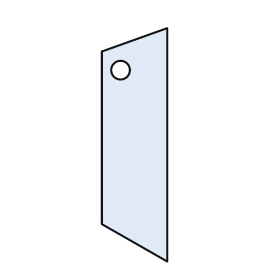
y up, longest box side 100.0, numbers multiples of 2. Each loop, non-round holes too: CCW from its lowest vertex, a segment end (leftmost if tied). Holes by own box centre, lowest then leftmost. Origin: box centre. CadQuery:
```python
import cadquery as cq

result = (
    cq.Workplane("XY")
    .moveTo(14.0, -50.0)
    .lineTo(14.0, 50.0)
    .lineTo(-14.0, 40.0)
    .lineTo(-14.0, -34.0)
    .close()
    .moveTo(-6.0, 32.0)
    .circle(4.0)
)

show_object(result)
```